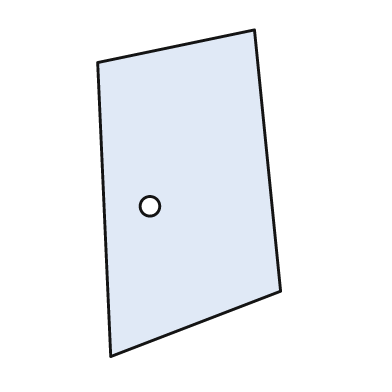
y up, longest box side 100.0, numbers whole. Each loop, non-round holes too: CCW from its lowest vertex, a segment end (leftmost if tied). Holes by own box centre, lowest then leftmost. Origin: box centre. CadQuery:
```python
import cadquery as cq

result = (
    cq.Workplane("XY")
    .moveTo(-24.0, -50.0)
    .lineTo(28.0, -30.0)
    .lineTo(20.0, 50.0)
    .lineTo(-28.0, 40.0)
    .close()
    .moveTo(-12.0, -4.0)
    .circle(3.0)
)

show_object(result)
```